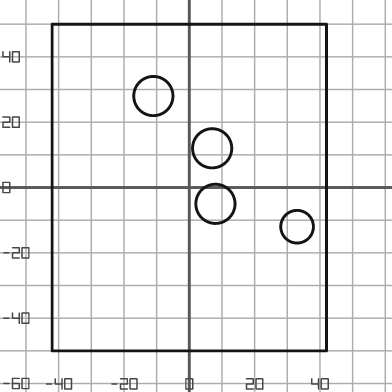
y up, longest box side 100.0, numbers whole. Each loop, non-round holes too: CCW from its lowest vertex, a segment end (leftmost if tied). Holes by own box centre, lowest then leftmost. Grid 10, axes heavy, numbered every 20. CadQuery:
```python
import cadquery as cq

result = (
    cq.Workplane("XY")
    .moveTo(-42.0, -50.0)
    .lineTo(42.0, -50.0)
    .lineTo(42.0, 50.0)
    .lineTo(-42.0, 50.0)
    .close()
    .moveTo(33.0, -12.0)
    .circle(5.0)
    .moveTo(8.0, -5.0)
    .circle(6.0)
    .moveTo(7.0, 12.0)
    .circle(6.0)
    .moveTo(-11.0, 28.0)
    .circle(6.0)
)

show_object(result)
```